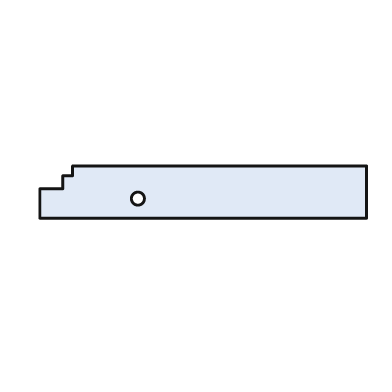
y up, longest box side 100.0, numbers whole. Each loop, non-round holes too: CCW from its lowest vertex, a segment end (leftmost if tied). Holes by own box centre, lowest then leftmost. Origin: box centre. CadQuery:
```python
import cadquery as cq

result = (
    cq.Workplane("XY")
    .moveTo(-50.0, -8.0)
    .lineTo(50.0, -8.0)
    .lineTo(50.0, 8.0)
    .lineTo(-40.0, 8.0)
    .lineTo(-40.0, 5.0)
    .lineTo(-43.0, 5.0)
    .lineTo(-43.0, 1.0)
    .lineTo(-50.0, 1.0)
    .close()
    .moveTo(-20.0, -2.0)
    .circle(2.0)
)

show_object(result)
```